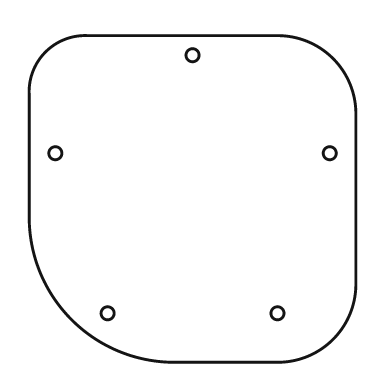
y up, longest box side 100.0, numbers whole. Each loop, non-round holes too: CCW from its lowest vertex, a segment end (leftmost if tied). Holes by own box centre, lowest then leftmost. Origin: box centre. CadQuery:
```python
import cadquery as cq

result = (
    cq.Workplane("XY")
    .moveTo(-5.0, -50.0)
    .lineTo(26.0, -50.0)
    .threePointArc((43.0, -43.0), (50.0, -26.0))
    .lineTo(50.0, 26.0)
    .threePointArc((43.0, 43.0), (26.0, 50.0))
    .lineTo(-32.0, 50.0)
    .threePointArc((-45.0, 45.0), (-50.0, 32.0))
    .lineTo(-50.0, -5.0)
    .threePointArc((-37.0, -37.0), (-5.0, -50.0))
    .close()
    .moveTo(-26.0, -35.0)
    .circle(2.0)
    .moveTo(26.0, -35.0)
    .circle(2.0)
    .moveTo(-42.0, 14.0)
    .circle(2.0)
    .moveTo(42.0, 14.0)
    .circle(2.0)
    .moveTo(0.0, 44.0)
    .circle(2.0)
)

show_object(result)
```